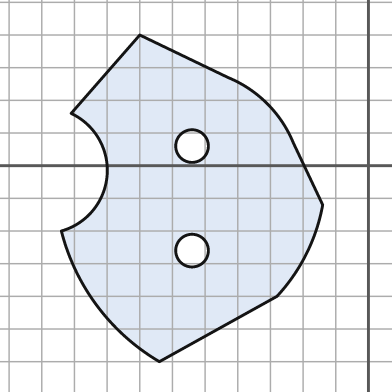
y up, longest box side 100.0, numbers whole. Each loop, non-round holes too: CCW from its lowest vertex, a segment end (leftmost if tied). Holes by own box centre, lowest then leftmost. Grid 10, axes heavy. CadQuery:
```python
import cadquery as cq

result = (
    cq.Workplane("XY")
    .moveTo(-64.0, -60.0)
    .lineTo(-28.0, -40.0)
    .threePointArc((-19.0, -27.0), (-14.0, -12.0))
    .lineTo(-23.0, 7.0)
    .threePointArc((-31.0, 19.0), (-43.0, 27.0))
    .lineTo(-70.0, 40.0)
    .lineTo(-91.0, 16.0)
    .threePointArc((-80.0, -3.0), (-94.0, -20.0))
    .threePointArc((-83.0, -43.0), (-64.0, -60.0))
    .close()
    .moveTo(-54.0, -26.0)
    .circle(5.0)
    .moveTo(-54.0, 6.0)
    .circle(5.0)
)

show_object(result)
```